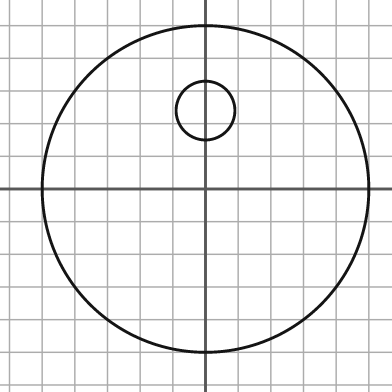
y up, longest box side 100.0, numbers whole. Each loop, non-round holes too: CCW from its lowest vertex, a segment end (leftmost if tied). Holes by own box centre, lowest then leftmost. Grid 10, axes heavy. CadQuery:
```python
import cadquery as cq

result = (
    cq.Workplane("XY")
    .moveTo(0.0, 0.0)
    .circle(50.0)
    .moveTo(0.0, 24.0)
    .circle(9.0)
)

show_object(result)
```